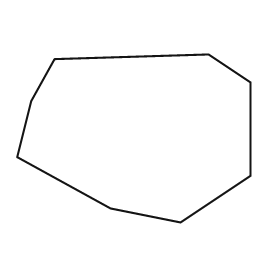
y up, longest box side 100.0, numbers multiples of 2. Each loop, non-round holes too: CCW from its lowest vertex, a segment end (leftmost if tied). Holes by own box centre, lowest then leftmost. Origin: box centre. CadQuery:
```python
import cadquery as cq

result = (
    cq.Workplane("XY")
    .moveTo(20.0, -36.0)
    .lineTo(50.0, -16.0)
    .lineTo(50.0, 24.0)
    .lineTo(32.0, 36.0)
    .lineTo(-34.0, 34.0)
    .lineTo(-44.0, 16.0)
    .lineTo(-50.0, -8.0)
    .lineTo(-10.0, -30.0)
    .close()
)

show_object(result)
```